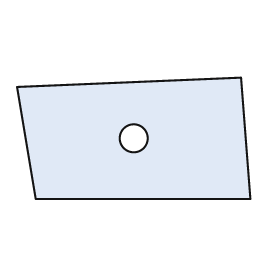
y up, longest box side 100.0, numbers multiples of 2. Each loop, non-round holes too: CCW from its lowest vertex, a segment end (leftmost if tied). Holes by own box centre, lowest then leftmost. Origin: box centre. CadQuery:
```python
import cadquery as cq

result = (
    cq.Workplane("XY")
    .moveTo(-42.0, -26.0)
    .lineTo(50.0, -26.0)
    .lineTo(46.0, 26.0)
    .lineTo(-50.0, 22.0)
    .close()
    .moveTo(0.0, 0.0)
    .circle(6.0)
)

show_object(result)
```